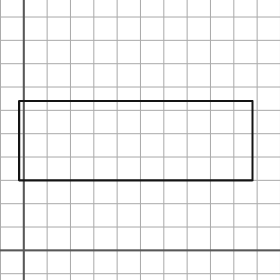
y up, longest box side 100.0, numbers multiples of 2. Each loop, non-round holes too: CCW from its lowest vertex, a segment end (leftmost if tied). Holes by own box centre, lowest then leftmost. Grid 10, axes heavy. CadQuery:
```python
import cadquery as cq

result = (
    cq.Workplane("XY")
    .moveTo(-2.0, 30.0)
    .lineTo(98.0, 30.0)
    .lineTo(98.0, 64.0)
    .lineTo(-2.0, 64.0)
    .close()
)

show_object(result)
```